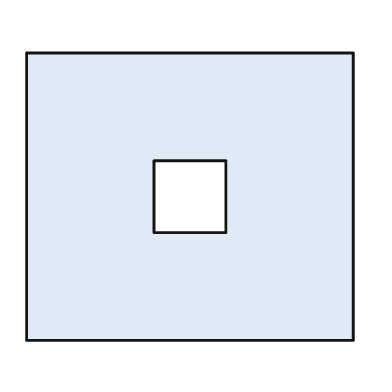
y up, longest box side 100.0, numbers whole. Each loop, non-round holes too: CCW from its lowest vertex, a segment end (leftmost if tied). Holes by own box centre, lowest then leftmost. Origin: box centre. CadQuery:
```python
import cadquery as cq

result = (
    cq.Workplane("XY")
    .moveTo(-50.0, -44.0)
    .lineTo(50.0, -44.0)
    .lineTo(50.0, 44.0)
    .lineTo(-50.0, 44.0)
    .close()
    .moveTo(-11.0, -11.0)
    .lineTo(11.0, -11.0)
    .lineTo(11.0, 11.0)
    .lineTo(-11.0, 11.0)
    .close()
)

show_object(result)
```